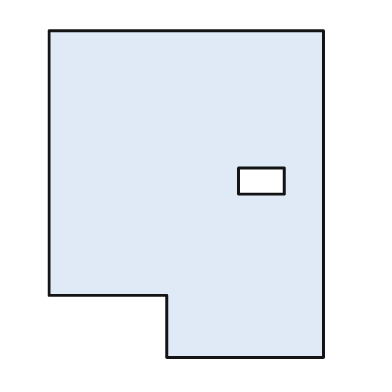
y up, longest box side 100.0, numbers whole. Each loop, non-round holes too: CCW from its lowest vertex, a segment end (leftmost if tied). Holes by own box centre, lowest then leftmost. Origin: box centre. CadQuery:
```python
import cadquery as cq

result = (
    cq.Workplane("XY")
    .moveTo(-6.0, -50.0)
    .lineTo(42.0, -50.0)
    .lineTo(42.0, 50.0)
    .lineTo(-42.0, 50.0)
    .lineTo(-42.0, -31.0)
    .lineTo(-6.0, -31.0)
    .close()
    .moveTo(16.0, 0.0)
    .lineTo(30.0, 0.0)
    .lineTo(30.0, 8.0)
    .lineTo(16.0, 8.0)
    .close()
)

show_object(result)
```